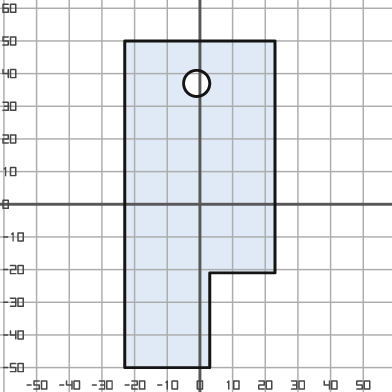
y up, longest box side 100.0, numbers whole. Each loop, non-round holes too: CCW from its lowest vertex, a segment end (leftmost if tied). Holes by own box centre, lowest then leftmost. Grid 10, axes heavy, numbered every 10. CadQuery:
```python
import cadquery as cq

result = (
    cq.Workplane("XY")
    .moveTo(-23.0, -50.0)
    .lineTo(3.0, -50.0)
    .lineTo(3.0, -21.0)
    .lineTo(23.0, -21.0)
    .lineTo(23.0, 50.0)
    .lineTo(-23.0, 50.0)
    .close()
    .moveTo(-1.0, 37.0)
    .circle(4.0)
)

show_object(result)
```